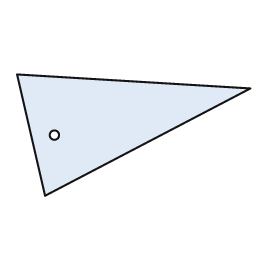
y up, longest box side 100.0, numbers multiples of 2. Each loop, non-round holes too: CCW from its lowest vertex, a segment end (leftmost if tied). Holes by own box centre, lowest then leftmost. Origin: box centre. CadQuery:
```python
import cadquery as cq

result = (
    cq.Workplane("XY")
    .moveTo(-38.0, -26.0)
    .lineTo(50.0, 20.0)
    .lineTo(-50.0, 26.0)
    .close()
    .moveTo(-34.0, 0.0)
    .circle(2.0)
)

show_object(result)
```